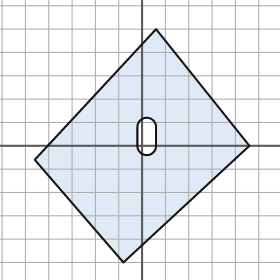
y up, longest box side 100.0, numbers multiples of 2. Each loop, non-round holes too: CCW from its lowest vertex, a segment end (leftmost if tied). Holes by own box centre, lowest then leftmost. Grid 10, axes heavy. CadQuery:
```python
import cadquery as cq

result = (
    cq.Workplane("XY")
    .moveTo(-8.0, -50.0)
    .lineTo(46.0, 0.0)
    .lineTo(6.0, 50.0)
    .lineTo(-46.0, -6.0)
    .close()
    .moveTo(-2.0, 0.0)
    .threePointArc((2.0, -4.0), (6.0, 0.0))
    .lineTo(6.0, 8.0)
    .threePointArc((2.0, 12.0), (-2.0, 8.0))
    .close()
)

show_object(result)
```